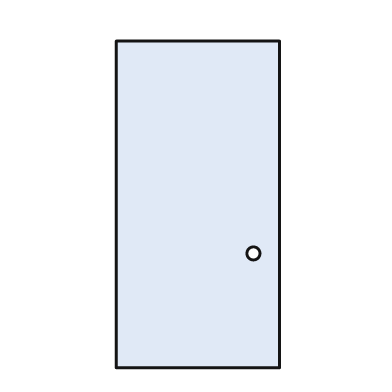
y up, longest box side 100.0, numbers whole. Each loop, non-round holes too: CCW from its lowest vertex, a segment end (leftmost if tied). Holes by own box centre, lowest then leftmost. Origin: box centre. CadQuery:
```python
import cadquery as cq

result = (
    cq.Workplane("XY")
    .moveTo(-25.0, -50.0)
    .lineTo(25.0, -50.0)
    .lineTo(25.0, 50.0)
    .lineTo(-25.0, 50.0)
    .close()
    .moveTo(17.0, -15.0)
    .circle(2.0)
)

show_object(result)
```